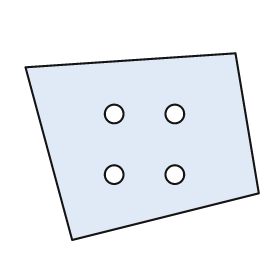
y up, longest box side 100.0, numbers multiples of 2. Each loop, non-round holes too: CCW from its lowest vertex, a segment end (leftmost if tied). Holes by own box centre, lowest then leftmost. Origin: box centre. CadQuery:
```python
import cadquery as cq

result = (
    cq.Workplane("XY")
    .moveTo(-30.0, -40.0)
    .lineTo(50.0, -20.0)
    .lineTo(40.0, 40.0)
    .lineTo(-50.0, 34.0)
    .close()
    .moveTo(-12.0, -12.0)
    .circle(4.0)
    .moveTo(14.0, -12.0)
    .circle(4.0)
    .moveTo(-12.0, 14.0)
    .circle(4.0)
    .moveTo(14.0, 14.0)
    .circle(4.0)
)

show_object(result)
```